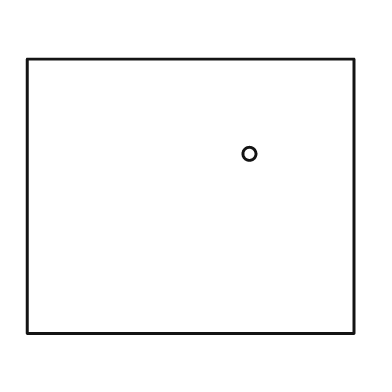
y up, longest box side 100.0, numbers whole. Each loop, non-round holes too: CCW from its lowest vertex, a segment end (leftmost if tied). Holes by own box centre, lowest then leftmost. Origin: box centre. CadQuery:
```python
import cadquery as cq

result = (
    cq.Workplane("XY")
    .moveTo(-50.0, -42.0)
    .lineTo(50.0, -42.0)
    .lineTo(50.0, 42.0)
    .lineTo(-50.0, 42.0)
    .close()
    .moveTo(18.0, 13.0)
    .circle(2.0)
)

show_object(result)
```